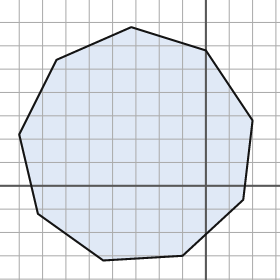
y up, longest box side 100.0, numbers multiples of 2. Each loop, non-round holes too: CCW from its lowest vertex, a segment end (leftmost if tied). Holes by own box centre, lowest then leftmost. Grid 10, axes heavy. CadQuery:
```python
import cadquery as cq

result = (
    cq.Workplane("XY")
    .moveTo(-44.0, -32.0)
    .lineTo(-10.0, -30.0)
    .lineTo(16.0, -6.0)
    .lineTo(20.0, 28.0)
    .lineTo(0.0, 58.0)
    .lineTo(-32.0, 68.0)
    .lineTo(-64.0, 54.0)
    .lineTo(-80.0, 22.0)
    .lineTo(-72.0, -12.0)
    .close()
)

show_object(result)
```